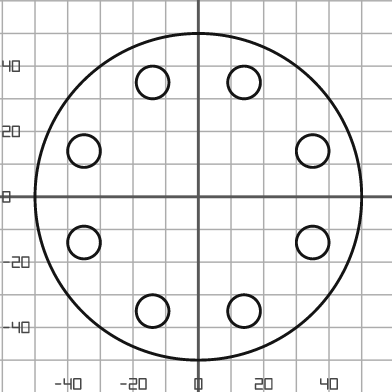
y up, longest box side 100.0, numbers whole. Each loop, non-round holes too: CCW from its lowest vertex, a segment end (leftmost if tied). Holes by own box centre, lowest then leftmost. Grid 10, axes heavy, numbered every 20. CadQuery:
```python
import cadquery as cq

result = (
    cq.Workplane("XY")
    .moveTo(0.0, 0.0)
    .circle(50.0)
    .moveTo(-14.0, -35.0)
    .circle(5.0)
    .moveTo(14.0, -35.0)
    .circle(5.0)
    .moveTo(-35.0, -14.0)
    .circle(5.0)
    .moveTo(35.0, -14.0)
    .circle(5.0)
    .moveTo(-35.0, 14.0)
    .circle(5.0)
    .moveTo(35.0, 14.0)
    .circle(5.0)
    .moveTo(-14.0, 35.0)
    .circle(5.0)
    .moveTo(14.0, 35.0)
    .circle(5.0)
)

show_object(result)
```